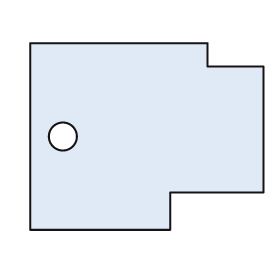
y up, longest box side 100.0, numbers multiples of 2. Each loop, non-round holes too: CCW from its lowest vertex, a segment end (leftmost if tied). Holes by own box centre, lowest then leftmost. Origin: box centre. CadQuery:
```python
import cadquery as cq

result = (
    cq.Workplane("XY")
    .moveTo(-50.0, -40.0)
    .lineTo(10.0, -40.0)
    .lineTo(10.0, -24.0)
    .lineTo(50.0, -24.0)
    .lineTo(50.0, 30.0)
    .lineTo(26.0, 30.0)
    .lineTo(26.0, 40.0)
    .lineTo(-50.0, 40.0)
    .close()
    .moveTo(-36.0, 0.0)
    .circle(6.0)
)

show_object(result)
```